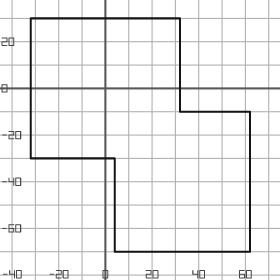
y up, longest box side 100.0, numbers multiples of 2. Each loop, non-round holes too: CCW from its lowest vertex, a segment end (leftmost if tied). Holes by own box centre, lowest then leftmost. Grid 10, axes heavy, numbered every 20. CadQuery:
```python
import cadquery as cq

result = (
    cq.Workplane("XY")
    .moveTo(4.0, -70.0)
    .lineTo(62.0, -70.0)
    .lineTo(62.0, -10.0)
    .lineTo(32.0, -10.0)
    .lineTo(32.0, 30.0)
    .lineTo(-32.0, 30.0)
    .lineTo(-32.0, -30.0)
    .lineTo(4.0, -30.0)
    .close()
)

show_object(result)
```